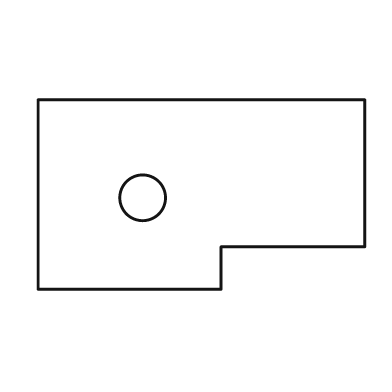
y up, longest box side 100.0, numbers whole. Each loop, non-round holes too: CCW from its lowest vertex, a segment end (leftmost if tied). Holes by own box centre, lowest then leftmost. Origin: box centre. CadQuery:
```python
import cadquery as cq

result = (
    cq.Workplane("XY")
    .moveTo(-50.0, -29.0)
    .lineTo(6.0, -29.0)
    .lineTo(6.0, -16.0)
    .lineTo(50.0, -16.0)
    .lineTo(50.0, 29.0)
    .lineTo(-50.0, 29.0)
    .close()
    .moveTo(-18.0, -1.0)
    .circle(7.0)
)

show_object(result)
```